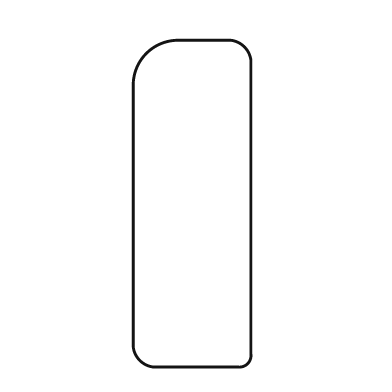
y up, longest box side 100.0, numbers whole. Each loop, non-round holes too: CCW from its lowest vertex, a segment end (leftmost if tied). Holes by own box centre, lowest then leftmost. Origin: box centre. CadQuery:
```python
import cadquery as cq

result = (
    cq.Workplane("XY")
    .moveTo(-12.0, -50.0)
    .lineTo(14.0, -50.0)
    .threePointArc((17.0, -49.0), (18.0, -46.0))
    .lineTo(18.0, 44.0)
    .threePointArc((16.0, 48.0), (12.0, 50.0))
    .lineTo(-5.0, 50.0)
    .threePointArc((-14.0, 46.0), (-18.0, 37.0))
    .lineTo(-18.0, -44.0)
    .threePointArc((-16.0, -48.0), (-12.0, -50.0))
    .close()
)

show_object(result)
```